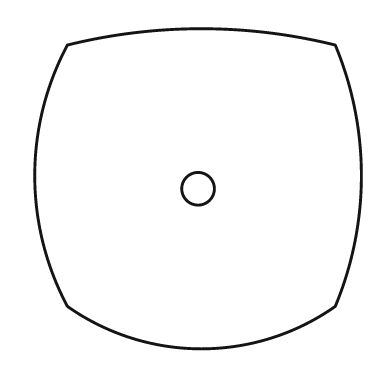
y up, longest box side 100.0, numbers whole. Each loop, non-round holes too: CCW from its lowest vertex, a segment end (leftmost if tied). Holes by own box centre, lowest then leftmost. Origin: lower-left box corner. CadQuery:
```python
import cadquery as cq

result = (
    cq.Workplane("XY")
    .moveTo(10.0, 13.0)
    .threePointArc((51.0, 0.0), (92.0, 13.0))
    .threePointArc((100.0, 53.0), (92.0, 93.0))
    .threePointArc((51.0, 98.0), (10.0, 93.0))
    .threePointArc((0.0, 53.0), (10.0, 13.0))
    .close()
    .moveTo(50.0, 49.0)
    .circle(5.0)
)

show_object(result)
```